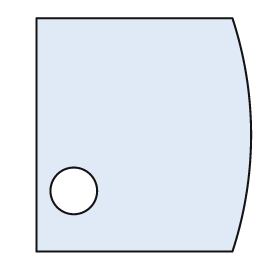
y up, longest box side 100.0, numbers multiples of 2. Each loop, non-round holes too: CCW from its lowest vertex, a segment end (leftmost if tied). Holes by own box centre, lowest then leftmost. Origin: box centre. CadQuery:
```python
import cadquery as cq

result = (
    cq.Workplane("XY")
    .moveTo(-46.0, -50.0)
    .lineTo(38.0, -50.0)
    .threePointArc((46.0, 0.0), (38.0, 50.0))
    .lineTo(-46.0, 50.0)
    .close()
    .moveTo(-30.0, -24.0)
    .circle(10.0)
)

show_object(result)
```